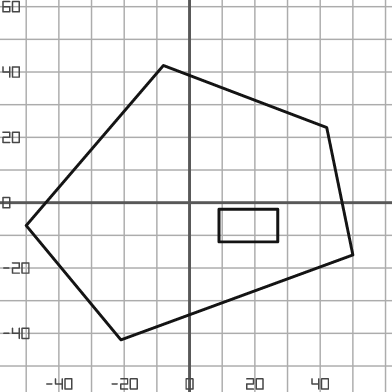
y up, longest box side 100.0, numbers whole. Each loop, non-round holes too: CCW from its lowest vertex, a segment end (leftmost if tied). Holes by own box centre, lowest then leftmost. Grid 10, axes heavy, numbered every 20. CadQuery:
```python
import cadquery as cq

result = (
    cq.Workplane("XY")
    .moveTo(-21.0, -42.0)
    .lineTo(50.0, -16.0)
    .lineTo(42.0, 23.0)
    .lineTo(-8.0, 42.0)
    .lineTo(-50.0, -7.0)
    .close()
    .moveTo(9.0, -12.0)
    .lineTo(27.0, -12.0)
    .lineTo(27.0, -2.0)
    .lineTo(9.0, -2.0)
    .close()
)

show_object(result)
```